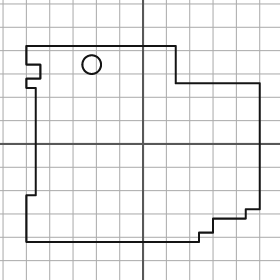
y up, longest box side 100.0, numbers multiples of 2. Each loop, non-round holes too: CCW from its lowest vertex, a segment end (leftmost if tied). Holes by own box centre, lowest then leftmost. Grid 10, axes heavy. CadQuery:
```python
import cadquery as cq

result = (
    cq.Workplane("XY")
    .moveTo(-50.0, -42.0)
    .lineTo(24.0, -42.0)
    .lineTo(24.0, -38.0)
    .lineTo(30.0, -38.0)
    .lineTo(30.0, -32.0)
    .lineTo(44.0, -32.0)
    .lineTo(44.0, -28.0)
    .lineTo(50.0, -28.0)
    .lineTo(50.0, 26.0)
    .lineTo(14.0, 26.0)
    .lineTo(14.0, 42.0)
    .lineTo(-50.0, 42.0)
    .lineTo(-50.0, 34.0)
    .lineTo(-44.0, 34.0)
    .lineTo(-44.0, 28.0)
    .lineTo(-50.0, 28.0)
    .lineTo(-50.0, 24.0)
    .lineTo(-46.0, 24.0)
    .lineTo(-46.0, -22.0)
    .lineTo(-50.0, -22.0)
    .close()
    .moveTo(-22.0, 34.0)
    .circle(4.0)
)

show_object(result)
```